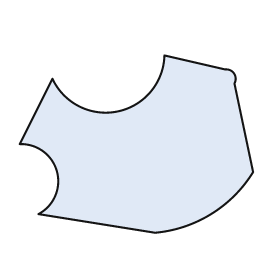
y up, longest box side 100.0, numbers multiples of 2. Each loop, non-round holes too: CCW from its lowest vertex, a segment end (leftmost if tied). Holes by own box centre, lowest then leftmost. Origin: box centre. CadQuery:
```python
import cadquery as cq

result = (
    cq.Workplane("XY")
    .moveTo(8.0, -38.0)
    .threePointArc((32.0, -30.0), (50.0, -12.0))
    .lineTo(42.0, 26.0)
    .threePointArc((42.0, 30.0), (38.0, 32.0))
    .lineTo(12.0, 38.0)
    .threePointArc((-8.0, 14.0), (-36.0, 28.0))
    .lineTo(-50.0, 0.0)
    .threePointArc((-34.0, -12.0), (-42.0, -30.0))
    .close()
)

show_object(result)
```